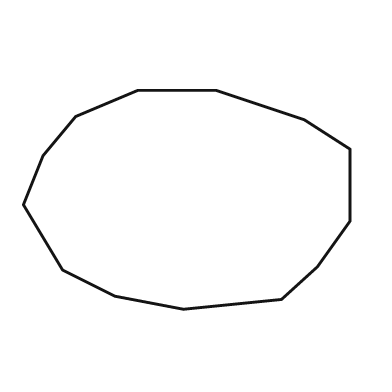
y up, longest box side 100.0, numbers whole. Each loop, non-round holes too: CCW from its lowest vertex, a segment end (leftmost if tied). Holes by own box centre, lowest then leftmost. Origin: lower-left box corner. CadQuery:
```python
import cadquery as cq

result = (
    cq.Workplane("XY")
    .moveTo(49.0, 0.0)
    .lineTo(79.0, 3.0)
    .lineTo(90.0, 13.0)
    .lineTo(100.0, 27.0)
    .lineTo(100.0, 49.0)
    .lineTo(86.0, 58.0)
    .lineTo(59.0, 67.0)
    .lineTo(35.0, 67.0)
    .lineTo(16.0, 59.0)
    .lineTo(6.0, 47.0)
    .lineTo(0.0, 32.0)
    .lineTo(12.0, 12.0)
    .lineTo(28.0, 4.0)
    .close()
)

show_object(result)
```